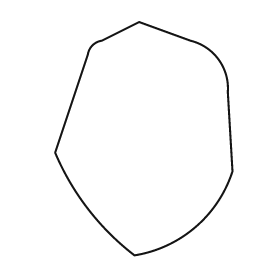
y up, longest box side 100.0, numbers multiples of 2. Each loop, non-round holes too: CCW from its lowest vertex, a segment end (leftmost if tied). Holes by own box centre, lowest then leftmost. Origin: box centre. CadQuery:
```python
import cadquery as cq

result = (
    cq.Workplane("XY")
    .moveTo(-4.0, -50.0)
    .threePointArc((22.0, -38.0), (38.0, -14.0))
    .lineTo(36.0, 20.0)
    .threePointArc((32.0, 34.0), (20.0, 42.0))
    .lineTo(-2.0, 50.0)
    .lineTo(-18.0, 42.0)
    .threePointArc((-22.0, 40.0), (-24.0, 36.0))
    .lineTo(-38.0, -6.0)
    .threePointArc((-24.0, -30.0), (-4.0, -50.0))
    .close()
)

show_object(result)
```